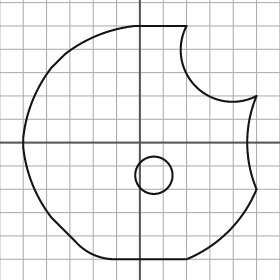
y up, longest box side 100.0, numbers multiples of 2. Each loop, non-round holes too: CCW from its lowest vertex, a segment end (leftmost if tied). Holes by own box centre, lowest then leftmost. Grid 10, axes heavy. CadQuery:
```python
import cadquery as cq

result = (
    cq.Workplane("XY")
    .moveTo(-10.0, -50.0)
    .lineTo(20.0, -50.0)
    .threePointArc((38.0, -38.0), (50.0, -20.0))
    .threePointArc((46.0, 0.0), (50.0, 20.0))
    .threePointArc((24.0, 24.0), (20.0, 50.0))
    .lineTo(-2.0, 50.0)
    .threePointArc((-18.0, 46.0), (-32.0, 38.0))
    .lineTo(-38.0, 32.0)
    .threePointArc((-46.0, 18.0), (-50.0, 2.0))
    .lineTo(-50.0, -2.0)
    .threePointArc((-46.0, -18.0), (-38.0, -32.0))
    .lineTo(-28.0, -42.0)
    .threePointArc((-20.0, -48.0), (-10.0, -50.0))
    .close()
    .moveTo(6.0, -14.0)
    .circle(8.0)
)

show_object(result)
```